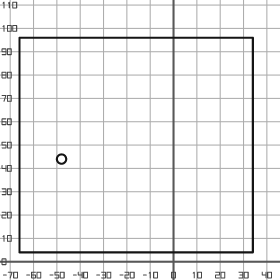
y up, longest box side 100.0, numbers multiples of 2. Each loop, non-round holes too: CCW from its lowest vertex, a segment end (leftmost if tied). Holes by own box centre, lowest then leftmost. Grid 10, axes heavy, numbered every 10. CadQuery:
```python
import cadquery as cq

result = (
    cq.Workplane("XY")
    .moveTo(-66.0, 4.0)
    .lineTo(34.0, 4.0)
    .lineTo(34.0, 96.0)
    .lineTo(-66.0, 96.0)
    .close()
    .moveTo(-48.0, 44.0)
    .circle(2.0)
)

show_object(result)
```